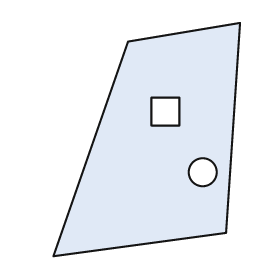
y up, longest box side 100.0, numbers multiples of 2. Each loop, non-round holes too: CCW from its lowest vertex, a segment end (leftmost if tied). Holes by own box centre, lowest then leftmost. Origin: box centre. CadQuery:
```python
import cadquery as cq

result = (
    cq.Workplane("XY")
    .moveTo(-40.0, -50.0)
    .lineTo(34.0, -40.0)
    .lineTo(40.0, 50.0)
    .lineTo(-8.0, 42.0)
    .close()
    .moveTo(24.0, -14.0)
    .circle(6.0)
    .moveTo(2.0, 6.0)
    .lineTo(14.0, 6.0)
    .lineTo(14.0, 18.0)
    .lineTo(2.0, 18.0)
    .close()
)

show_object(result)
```